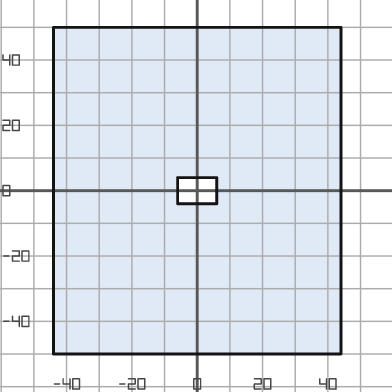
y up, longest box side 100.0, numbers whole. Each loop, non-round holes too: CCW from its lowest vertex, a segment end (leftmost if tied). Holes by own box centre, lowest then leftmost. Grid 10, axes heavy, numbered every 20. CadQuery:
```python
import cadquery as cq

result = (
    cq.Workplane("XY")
    .moveTo(-44.0, -50.0)
    .lineTo(44.0, -50.0)
    .lineTo(44.0, 50.0)
    .lineTo(-44.0, 50.0)
    .close()
    .moveTo(-6.0, -4.0)
    .lineTo(6.0, -4.0)
    .lineTo(6.0, 4.0)
    .lineTo(-6.0, 4.0)
    .close()
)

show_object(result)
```